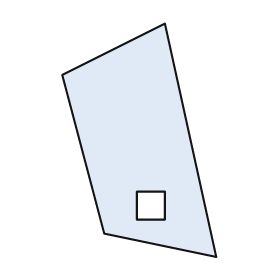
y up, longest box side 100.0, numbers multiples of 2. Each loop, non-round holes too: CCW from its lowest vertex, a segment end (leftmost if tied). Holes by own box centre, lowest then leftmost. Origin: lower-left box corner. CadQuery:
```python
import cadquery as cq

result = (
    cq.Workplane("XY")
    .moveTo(66.0, 0.0)
    .lineTo(44.0, 100.0)
    .lineTo(0.0, 78.0)
    .lineTo(18.0, 10.0)
    .close()
    .moveTo(32.0, 16.0)
    .lineTo(44.0, 16.0)
    .lineTo(44.0, 28.0)
    .lineTo(32.0, 28.0)
    .close()
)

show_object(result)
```